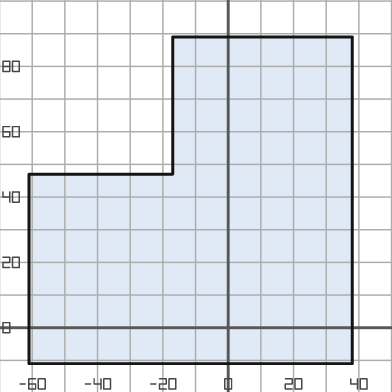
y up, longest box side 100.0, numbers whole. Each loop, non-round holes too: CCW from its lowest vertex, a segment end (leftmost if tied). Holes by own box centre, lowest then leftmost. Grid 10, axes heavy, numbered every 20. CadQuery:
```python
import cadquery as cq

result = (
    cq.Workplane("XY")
    .moveTo(-61.0, -11.0)
    .lineTo(38.0, -11.0)
    .lineTo(38.0, 89.0)
    .lineTo(-17.0, 89.0)
    .lineTo(-17.0, 47.0)
    .lineTo(-61.0, 47.0)
    .close()
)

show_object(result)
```